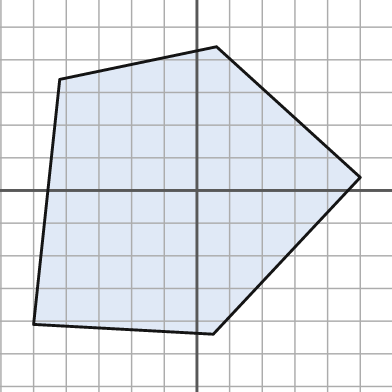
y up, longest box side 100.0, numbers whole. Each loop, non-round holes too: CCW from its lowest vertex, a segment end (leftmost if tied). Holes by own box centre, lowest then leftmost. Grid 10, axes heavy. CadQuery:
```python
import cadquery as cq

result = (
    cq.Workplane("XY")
    .moveTo(5.0, -44.0)
    .lineTo(50.0, 4.0)
    .lineTo(6.0, 44.0)
    .lineTo(-42.0, 34.0)
    .lineTo(-50.0, -41.0)
    .close()
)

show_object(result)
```